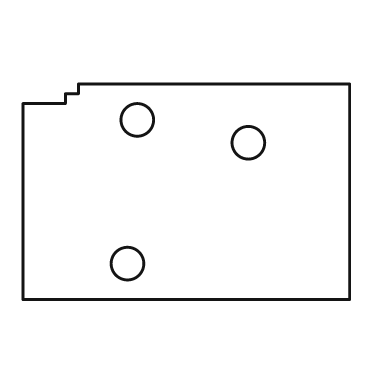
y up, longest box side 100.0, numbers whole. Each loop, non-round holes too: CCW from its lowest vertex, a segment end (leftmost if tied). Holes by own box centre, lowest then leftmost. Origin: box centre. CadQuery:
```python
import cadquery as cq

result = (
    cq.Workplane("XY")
    .moveTo(-50.0, -33.0)
    .lineTo(50.0, -33.0)
    .lineTo(50.0, 33.0)
    .lineTo(-33.0, 33.0)
    .lineTo(-33.0, 30.0)
    .lineTo(-37.0, 30.0)
    .lineTo(-37.0, 27.0)
    .lineTo(-50.0, 27.0)
    .close()
    .moveTo(-18.0, -22.0)
    .circle(5.0)
    .moveTo(19.0, 15.0)
    .circle(5.0)
    .moveTo(-15.0, 22.0)
    .circle(5.0)
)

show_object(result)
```